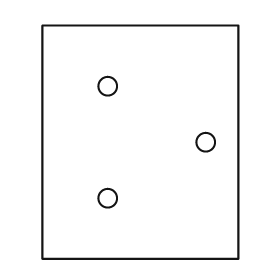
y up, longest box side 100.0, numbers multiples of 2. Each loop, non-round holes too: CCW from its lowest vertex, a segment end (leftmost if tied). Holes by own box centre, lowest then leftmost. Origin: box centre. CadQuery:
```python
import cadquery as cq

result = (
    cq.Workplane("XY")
    .moveTo(-42.0, -50.0)
    .lineTo(42.0, -50.0)
    .lineTo(42.0, 50.0)
    .lineTo(-42.0, 50.0)
    .close()
    .moveTo(-14.0, -24.0)
    .circle(4.0)
    .moveTo(28.0, 0.0)
    .circle(4.0)
    .moveTo(-14.0, 24.0)
    .circle(4.0)
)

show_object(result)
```